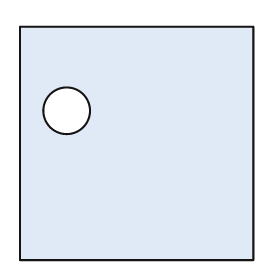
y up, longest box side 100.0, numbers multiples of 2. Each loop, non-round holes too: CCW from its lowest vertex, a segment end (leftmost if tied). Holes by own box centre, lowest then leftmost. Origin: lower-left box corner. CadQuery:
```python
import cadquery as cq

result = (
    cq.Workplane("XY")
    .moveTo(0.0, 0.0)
    .lineTo(100.0, 0.0)
    .lineTo(100.0, 100.0)
    .lineTo(0.0, 100.0)
    .close()
    .moveTo(20.0, 64.0)
    .circle(10.0)
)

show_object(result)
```